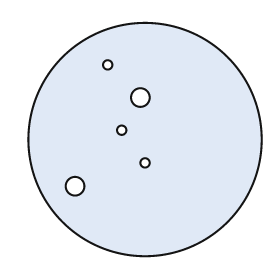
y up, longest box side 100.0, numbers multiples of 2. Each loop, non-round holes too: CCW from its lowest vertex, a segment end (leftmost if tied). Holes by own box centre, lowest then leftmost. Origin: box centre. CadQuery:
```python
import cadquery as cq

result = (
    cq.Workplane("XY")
    .moveTo(0.0, 0.0)
    .circle(50.0)
    .moveTo(-30.0, -20.0)
    .circle(4.0)
    .moveTo(0.0, -10.0)
    .circle(2.0)
    .moveTo(-10.0, 4.0)
    .circle(2.0)
    .moveTo(-2.0, 18.0)
    .circle(4.0)
    .moveTo(-16.0, 32.0)
    .circle(2.0)
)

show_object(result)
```